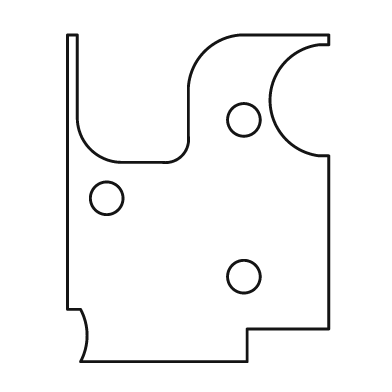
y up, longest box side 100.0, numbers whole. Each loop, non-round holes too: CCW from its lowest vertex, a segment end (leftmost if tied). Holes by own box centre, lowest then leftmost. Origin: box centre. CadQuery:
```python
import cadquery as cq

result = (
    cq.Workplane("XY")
    .moveTo(-36.0, -50.0)
    .lineTo(15.0, -50.0)
    .lineTo(15.0, -40.0)
    .lineTo(40.0, -40.0)
    .lineTo(40.0, 13.0)
    .lineTo(37.0, 13.0)
    .threePointArc((22.0, 30.0), (37.0, 47.0))
    .lineTo(40.0, 47.0)
    .lineTo(40.0, 50.0)
    .lineTo(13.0, 50.0)
    .threePointArc((2.0, 45.0), (-3.0, 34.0))
    .lineTo(-3.0, 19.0)
    .threePointArc((-5.0, 13.0), (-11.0, 11.0))
    .lineTo(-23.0, 11.0)
    .threePointArc((-33.0, 15.0), (-37.0, 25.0))
    .lineTo(-37.0, 50.0)
    .lineTo(-40.0, 50.0)
    .lineTo(-40.0, -34.0)
    .lineTo(-36.0, -34.0)
    .threePointArc((-34.0, -42.0), (-36.0, -50.0))
    .close()
    .moveTo(14.0, -24.0)
    .circle(5.0)
    .moveTo(-28.0, 0.0)
    .circle(5.0)
    .moveTo(14.0, 24.0)
    .circle(5.0)
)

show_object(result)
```